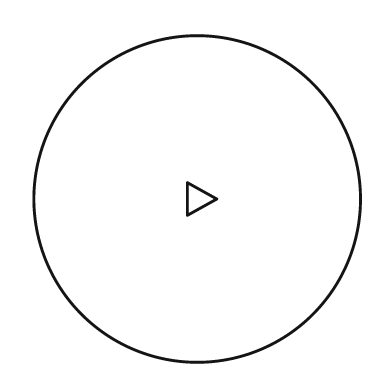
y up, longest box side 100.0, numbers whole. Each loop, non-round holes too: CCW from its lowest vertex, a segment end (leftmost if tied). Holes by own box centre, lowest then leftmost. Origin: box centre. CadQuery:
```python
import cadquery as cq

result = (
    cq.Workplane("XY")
    .moveTo(0.0, 0.0)
    .circle(50.0)
    .moveTo(-3.0, -5.0)
    .lineTo(6.0, 0.0)
    .lineTo(-3.0, 5.0)
    .close()
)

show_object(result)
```